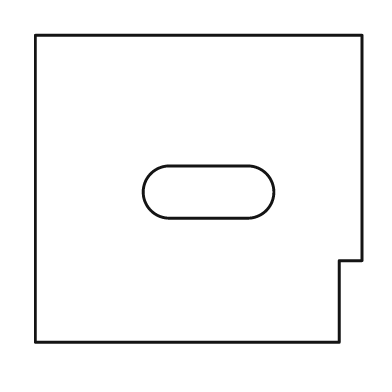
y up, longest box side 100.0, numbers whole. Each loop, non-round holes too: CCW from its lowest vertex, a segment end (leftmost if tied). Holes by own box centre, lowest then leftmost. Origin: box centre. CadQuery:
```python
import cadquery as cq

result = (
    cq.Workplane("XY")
    .moveTo(-50.0, -47.0)
    .lineTo(43.0, -47.0)
    .lineTo(43.0, -22.0)
    .lineTo(50.0, -22.0)
    .lineTo(50.0, 47.0)
    .lineTo(-50.0, 47.0)
    .close()
    .moveTo(-9.0, -9.0)
    .lineTo(15.0, -9.0)
    .threePointArc((23.0, -1.0), (15.0, 7.0))
    .lineTo(-9.0, 7.0)
    .threePointArc((-17.0, -1.0), (-9.0, -9.0))
    .close()
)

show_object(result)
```